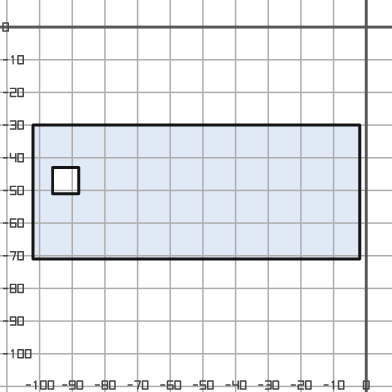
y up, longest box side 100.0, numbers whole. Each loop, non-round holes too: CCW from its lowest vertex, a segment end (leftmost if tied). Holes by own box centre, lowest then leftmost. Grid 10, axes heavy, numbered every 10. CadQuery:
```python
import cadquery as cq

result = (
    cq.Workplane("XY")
    .moveTo(-102.0, -71.0)
    .lineTo(-2.0, -71.0)
    .lineTo(-2.0, -30.0)
    .lineTo(-102.0, -30.0)
    .close()
    .moveTo(-96.0, -51.0)
    .lineTo(-88.0, -51.0)
    .lineTo(-88.0, -43.0)
    .lineTo(-96.0, -43.0)
    .close()
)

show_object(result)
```